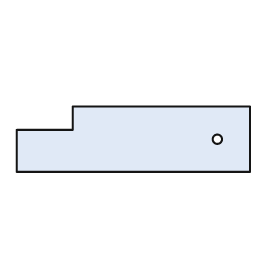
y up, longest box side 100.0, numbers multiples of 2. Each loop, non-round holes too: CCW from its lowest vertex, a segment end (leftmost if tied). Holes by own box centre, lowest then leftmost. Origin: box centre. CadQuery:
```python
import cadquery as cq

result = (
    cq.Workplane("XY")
    .moveTo(-50.0, -14.0)
    .lineTo(50.0, -14.0)
    .lineTo(50.0, 14.0)
    .lineTo(-26.0, 14.0)
    .lineTo(-26.0, 4.0)
    .lineTo(-50.0, 4.0)
    .close()
    .moveTo(36.0, 0.0)
    .circle(2.0)
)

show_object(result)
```